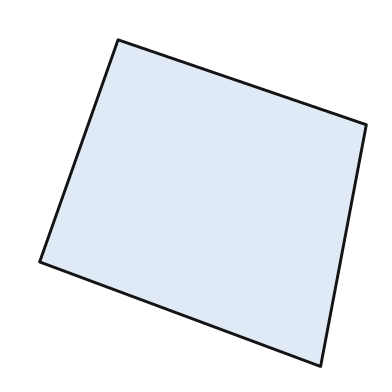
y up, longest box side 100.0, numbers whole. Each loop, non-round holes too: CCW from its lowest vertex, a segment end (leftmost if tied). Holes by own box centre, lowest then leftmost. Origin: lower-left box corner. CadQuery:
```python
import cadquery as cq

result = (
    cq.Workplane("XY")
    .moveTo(86.0, 0.0)
    .lineTo(100.0, 74.0)
    .lineTo(24.0, 100.0)
    .lineTo(0.0, 32.0)
    .close()
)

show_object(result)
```